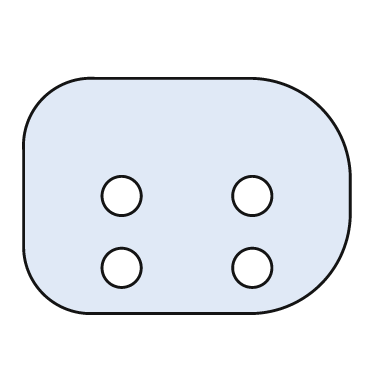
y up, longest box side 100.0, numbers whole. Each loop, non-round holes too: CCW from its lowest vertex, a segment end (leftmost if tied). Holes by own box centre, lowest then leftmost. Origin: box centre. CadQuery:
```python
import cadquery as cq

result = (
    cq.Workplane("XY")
    .moveTo(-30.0, -36.0)
    .lineTo(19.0, -36.0)
    .threePointArc((41.0, -27.0), (50.0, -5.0))
    .lineTo(50.0, 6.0)
    .threePointArc((41.0, 27.0), (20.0, 36.0))
    .lineTo(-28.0, 36.0)
    .threePointArc((-44.0, 30.0), (-50.0, 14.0))
    .lineTo(-50.0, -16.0)
    .threePointArc((-44.0, -30.0), (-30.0, -36.0))
    .close()
    .moveTo(-20.0, -22.0)
    .circle(6.0)
    .moveTo(20.0, -22.0)
    .circle(6.0)
    .moveTo(-20.0, 0.0)
    .circle(6.0)
    .moveTo(20.0, 0.0)
    .circle(6.0)
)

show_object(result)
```